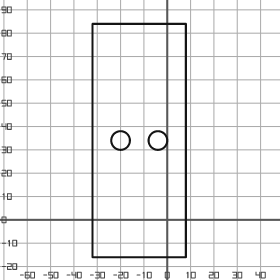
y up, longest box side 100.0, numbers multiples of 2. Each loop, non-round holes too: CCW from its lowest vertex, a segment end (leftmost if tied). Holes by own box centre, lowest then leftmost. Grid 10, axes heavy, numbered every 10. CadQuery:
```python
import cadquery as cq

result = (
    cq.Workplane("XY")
    .moveTo(-32.0, -16.0)
    .lineTo(8.0, -16.0)
    .lineTo(8.0, 84.0)
    .lineTo(-32.0, 84.0)
    .close()
    .moveTo(-20.0, 34.0)
    .circle(4.0)
    .moveTo(-4.0, 34.0)
    .circle(4.0)
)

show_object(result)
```